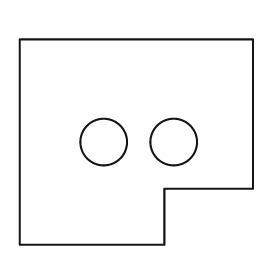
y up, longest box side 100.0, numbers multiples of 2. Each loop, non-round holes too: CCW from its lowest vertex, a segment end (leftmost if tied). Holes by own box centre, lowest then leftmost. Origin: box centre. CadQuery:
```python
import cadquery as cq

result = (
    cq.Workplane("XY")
    .moveTo(-50.0, -44.0)
    .lineTo(12.0, -44.0)
    .lineTo(12.0, -20.0)
    .lineTo(50.0, -20.0)
    .lineTo(50.0, 44.0)
    .lineTo(-50.0, 44.0)
    .close()
    .moveTo(-14.0, 0.0)
    .circle(10.0)
    .moveTo(16.0, 0.0)
    .circle(10.0)
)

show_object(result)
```